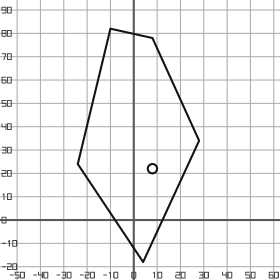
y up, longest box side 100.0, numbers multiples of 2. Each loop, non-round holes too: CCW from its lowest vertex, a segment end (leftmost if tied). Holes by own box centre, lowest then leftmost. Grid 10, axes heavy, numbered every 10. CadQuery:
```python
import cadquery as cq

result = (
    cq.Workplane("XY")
    .moveTo(4.0, -18.0)
    .lineTo(28.0, 34.0)
    .lineTo(8.0, 78.0)
    .lineTo(-10.0, 82.0)
    .lineTo(-24.0, 24.0)
    .close()
    .moveTo(8.0, 22.0)
    .circle(2.0)
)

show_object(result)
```